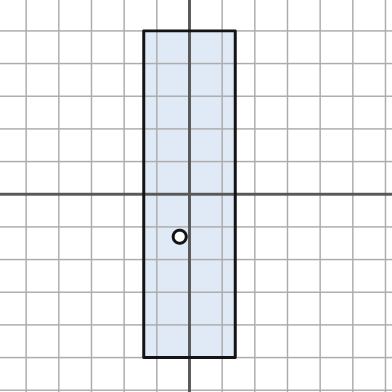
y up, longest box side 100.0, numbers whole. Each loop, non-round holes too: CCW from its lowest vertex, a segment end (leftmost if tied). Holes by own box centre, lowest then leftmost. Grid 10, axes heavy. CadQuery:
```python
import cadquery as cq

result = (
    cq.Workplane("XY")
    .moveTo(-14.0, -50.0)
    .lineTo(14.0, -50.0)
    .lineTo(14.0, 50.0)
    .lineTo(-14.0, 50.0)
    .close()
    .moveTo(-3.0, -13.0)
    .circle(2.0)
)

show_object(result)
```